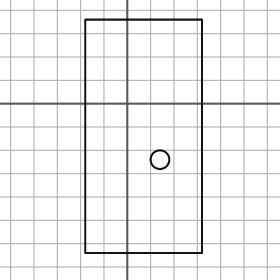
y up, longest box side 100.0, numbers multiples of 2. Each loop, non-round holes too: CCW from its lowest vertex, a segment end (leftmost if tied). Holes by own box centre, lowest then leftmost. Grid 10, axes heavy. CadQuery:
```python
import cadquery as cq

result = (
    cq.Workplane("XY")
    .moveTo(-18.0, -64.0)
    .lineTo(32.0, -64.0)
    .lineTo(32.0, 36.0)
    .lineTo(-18.0, 36.0)
    .close()
    .moveTo(14.0, -24.0)
    .circle(4.0)
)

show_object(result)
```